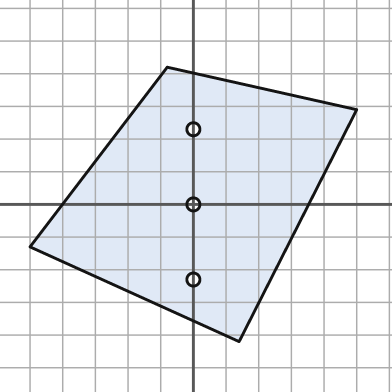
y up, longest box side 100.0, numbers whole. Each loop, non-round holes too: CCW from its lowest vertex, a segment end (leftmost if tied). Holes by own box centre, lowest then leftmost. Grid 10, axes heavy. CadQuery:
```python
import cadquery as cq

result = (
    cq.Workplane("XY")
    .moveTo(14.0, -42.0)
    .lineTo(50.0, 29.0)
    .lineTo(-8.0, 42.0)
    .lineTo(-50.0, -13.0)
    .close()
    .moveTo(0.0, -23.0)
    .circle(2.0)
    .moveTo(0.0, 0.0)
    .circle(2.0)
    .moveTo(0.0, 23.0)
    .circle(2.0)
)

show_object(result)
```